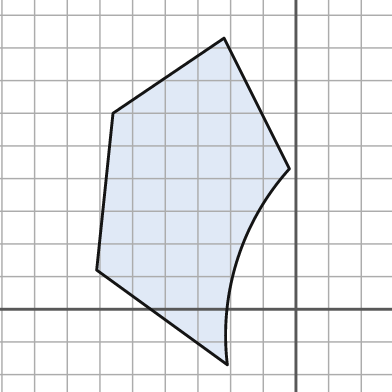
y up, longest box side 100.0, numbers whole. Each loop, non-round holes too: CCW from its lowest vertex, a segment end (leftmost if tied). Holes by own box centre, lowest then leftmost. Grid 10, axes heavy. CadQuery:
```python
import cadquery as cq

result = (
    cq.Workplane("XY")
    .moveTo(-21.0, -17.0)
    .threePointArc((-18.0, 15.0), (-2.0, 43.0))
    .lineTo(-22.0, 83.0)
    .lineTo(-56.0, 60.0)
    .lineTo(-61.0, 12.0)
    .close()
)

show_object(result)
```